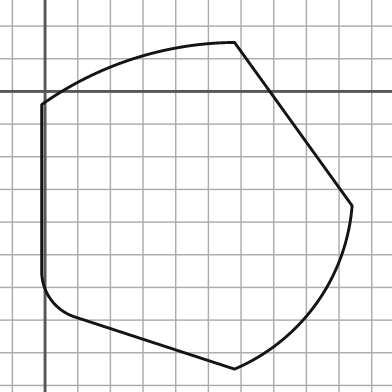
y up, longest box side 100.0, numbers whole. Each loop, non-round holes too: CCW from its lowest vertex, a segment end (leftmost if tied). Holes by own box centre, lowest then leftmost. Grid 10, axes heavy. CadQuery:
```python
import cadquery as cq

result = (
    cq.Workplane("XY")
    .moveTo(58.0, -85.0)
    .threePointArc((83.0, -65.0), (94.0, -35.0))
    .lineTo(58.0, 15.0)
    .threePointArc((27.0, 10.0), (-1.0, -4.0))
    .lineTo(-1.0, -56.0)
    .threePointArc((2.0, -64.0), (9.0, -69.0))
    .close()
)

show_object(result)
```